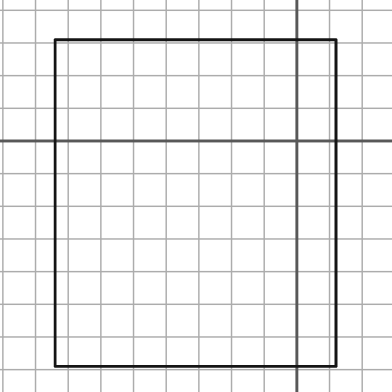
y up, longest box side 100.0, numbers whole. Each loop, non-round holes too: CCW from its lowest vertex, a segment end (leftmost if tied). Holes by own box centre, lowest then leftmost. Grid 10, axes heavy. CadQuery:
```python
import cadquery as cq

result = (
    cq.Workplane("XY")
    .moveTo(-74.0, -69.0)
    .lineTo(12.0, -69.0)
    .lineTo(12.0, 31.0)
    .lineTo(-74.0, 31.0)
    .close()
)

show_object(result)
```